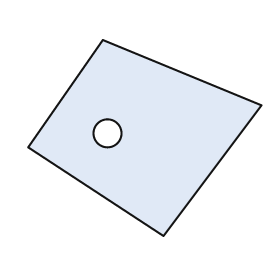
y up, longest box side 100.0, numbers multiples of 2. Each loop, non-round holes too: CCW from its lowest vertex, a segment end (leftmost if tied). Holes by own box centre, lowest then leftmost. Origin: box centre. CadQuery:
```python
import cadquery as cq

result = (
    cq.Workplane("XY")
    .moveTo(8.0, -42.0)
    .lineTo(50.0, 14.0)
    .lineTo(-18.0, 42.0)
    .lineTo(-50.0, -4.0)
    .close()
    .moveTo(-16.0, 2.0)
    .circle(6.0)
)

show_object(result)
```